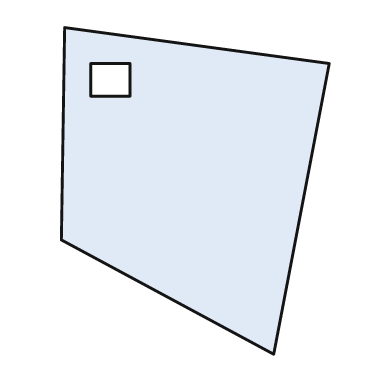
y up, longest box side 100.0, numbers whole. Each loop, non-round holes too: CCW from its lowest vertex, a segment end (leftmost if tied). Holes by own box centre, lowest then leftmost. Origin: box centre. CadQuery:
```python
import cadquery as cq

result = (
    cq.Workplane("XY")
    .moveTo(24.0, -50.0)
    .lineTo(41.0, 39.0)
    .lineTo(-40.0, 50.0)
    .lineTo(-41.0, -15.0)
    .close()
    .moveTo(-32.0, 29.0)
    .lineTo(-20.0, 29.0)
    .lineTo(-20.0, 39.0)
    .lineTo(-32.0, 39.0)
    .close()
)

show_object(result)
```